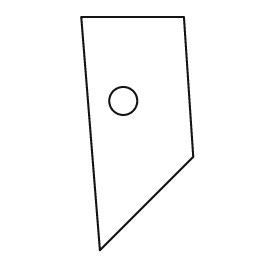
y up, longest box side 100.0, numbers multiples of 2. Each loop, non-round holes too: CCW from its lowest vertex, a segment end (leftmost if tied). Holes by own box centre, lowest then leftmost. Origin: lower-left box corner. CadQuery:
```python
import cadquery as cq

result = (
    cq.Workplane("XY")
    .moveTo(8.0, 0.0)
    .lineTo(48.0, 40.0)
    .lineTo(44.0, 100.0)
    .lineTo(0.0, 100.0)
    .close()
    .moveTo(18.0, 64.0)
    .circle(6.0)
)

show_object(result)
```